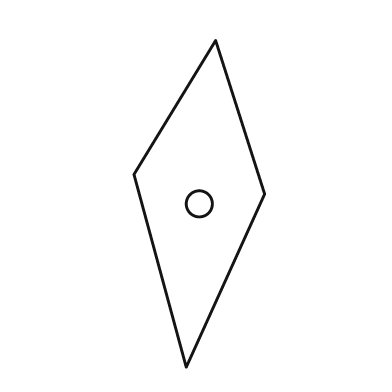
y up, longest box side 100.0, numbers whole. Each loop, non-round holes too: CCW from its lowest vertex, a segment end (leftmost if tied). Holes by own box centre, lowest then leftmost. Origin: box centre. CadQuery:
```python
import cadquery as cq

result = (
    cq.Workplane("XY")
    .moveTo(-4.0, -50.0)
    .lineTo(20.0, 3.0)
    .lineTo(5.0, 50.0)
    .lineTo(-20.0, 9.0)
    .close()
    .moveTo(0.0, 0.0)
    .circle(4.0)
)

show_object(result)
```